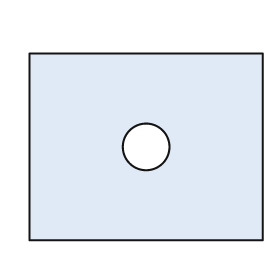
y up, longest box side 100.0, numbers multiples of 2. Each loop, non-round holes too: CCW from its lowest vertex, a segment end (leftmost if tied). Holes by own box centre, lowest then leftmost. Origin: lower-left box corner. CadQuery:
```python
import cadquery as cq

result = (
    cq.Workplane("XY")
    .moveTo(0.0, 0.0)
    .lineTo(100.0, 0.0)
    .lineTo(100.0, 80.0)
    .lineTo(0.0, 80.0)
    .close()
    .moveTo(50.0, 40.0)
    .circle(10.0)
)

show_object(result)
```